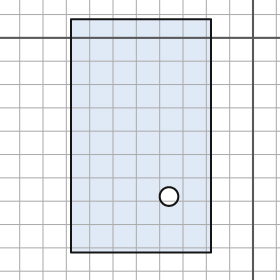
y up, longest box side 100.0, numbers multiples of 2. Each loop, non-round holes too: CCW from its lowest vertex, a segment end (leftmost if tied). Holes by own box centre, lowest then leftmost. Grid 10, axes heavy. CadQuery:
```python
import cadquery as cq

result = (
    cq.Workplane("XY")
    .moveTo(-78.0, -92.0)
    .lineTo(-18.0, -92.0)
    .lineTo(-18.0, 8.0)
    .lineTo(-78.0, 8.0)
    .close()
    .moveTo(-36.0, -68.0)
    .circle(4.0)
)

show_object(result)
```